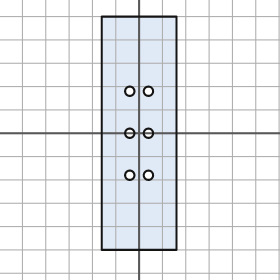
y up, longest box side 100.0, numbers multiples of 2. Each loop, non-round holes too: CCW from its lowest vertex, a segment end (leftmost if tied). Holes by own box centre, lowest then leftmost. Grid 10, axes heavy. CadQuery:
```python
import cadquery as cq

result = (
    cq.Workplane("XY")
    .moveTo(-16.0, -50.0)
    .lineTo(16.0, -50.0)
    .lineTo(16.0, 50.0)
    .lineTo(-16.0, 50.0)
    .close()
    .moveTo(-4.0, -18.0)
    .circle(2.0)
    .moveTo(4.0, -18.0)
    .circle(2.0)
    .moveTo(-4.0, 0.0)
    .circle(2.0)
    .moveTo(4.0, 0.0)
    .circle(2.0)
    .moveTo(-4.0, 18.0)
    .circle(2.0)
    .moveTo(4.0, 18.0)
    .circle(2.0)
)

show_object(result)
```